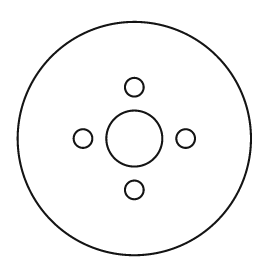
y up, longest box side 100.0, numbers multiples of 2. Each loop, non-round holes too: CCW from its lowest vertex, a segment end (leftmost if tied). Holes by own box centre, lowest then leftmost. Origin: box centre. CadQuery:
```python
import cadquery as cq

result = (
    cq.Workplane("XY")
    .moveTo(0.0, 0.0)
    .circle(50.0)
    .moveTo(0.0, -22.0)
    .circle(4.0)
    .moveTo(-22.0, 0.0)
    .circle(4.0)
    .moveTo(0.0, 0.0)
    .circle(12.0)
    .moveTo(22.0, 0.0)
    .circle(4.0)
    .moveTo(0.0, 22.0)
    .circle(4.0)
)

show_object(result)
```